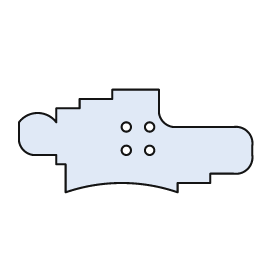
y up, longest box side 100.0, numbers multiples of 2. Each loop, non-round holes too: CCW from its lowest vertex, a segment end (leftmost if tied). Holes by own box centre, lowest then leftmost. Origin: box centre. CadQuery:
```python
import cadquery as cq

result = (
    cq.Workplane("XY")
    .moveTo(-30.0, -22.0)
    .threePointArc((-6.0, -18.0), (18.0, -22.0))
    .lineTo(18.0, -18.0)
    .lineTo(32.0, -18.0)
    .lineTo(32.0, -14.0)
    .lineTo(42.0, -14.0)
    .threePointArc((48.0, -12.0), (50.0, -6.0))
    .lineTo(50.0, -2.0)
    .threePointArc((48.0, 4.0), (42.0, 6.0))
    .lineTo(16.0, 6.0)
    .threePointArc((12.0, 8.0), (10.0, 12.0))
    .lineTo(10.0, 22.0)
    .lineTo(-10.0, 22.0)
    .lineTo(-10.0, 18.0)
    .lineTo(-24.0, 18.0)
    .lineTo(-24.0, 14.0)
    .lineTo(-34.0, 14.0)
    .lineTo(-34.0, 8.0)
    .threePointArc((-42.0, 12.0), (-50.0, 8.0))
    .lineTo(-50.0, 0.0)
    .threePointArc((-48.0, -4.0), (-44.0, -6.0))
    .lineTo(-34.0, -6.0)
    .lineTo(-34.0, -10.0)
    .lineTo(-30.0, -10.0)
    .close()
    .moveTo(-4.0, -4.0)
    .circle(2.0)
    .moveTo(6.0, -4.0)
    .circle(2.0)
    .moveTo(-4.0, 6.0)
    .circle(2.0)
    .moveTo(6.0, 6.0)
    .circle(2.0)
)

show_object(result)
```